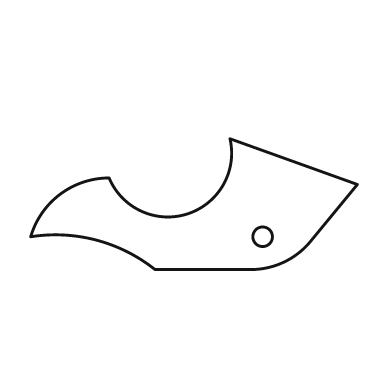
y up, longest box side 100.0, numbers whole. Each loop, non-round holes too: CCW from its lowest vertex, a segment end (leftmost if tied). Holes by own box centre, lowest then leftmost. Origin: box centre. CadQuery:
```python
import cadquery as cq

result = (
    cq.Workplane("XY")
    .moveTo(-12.0, -20.0)
    .lineTo(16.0, -20.0)
    .threePointArc((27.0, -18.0), (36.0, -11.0))
    .lineTo(50.0, 6.0)
    .lineTo(11.0, 20.0)
    .threePointArc((-2.0, -3.0), (-26.0, 8.0))
    .threePointArc((-41.0, 3.0), (-50.0, -10.0))
    .threePointArc((-30.0, -11.0), (-12.0, -20.0))
    .close()
    .moveTo(21.0, -10.0)
    .circle(3.0)
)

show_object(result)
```